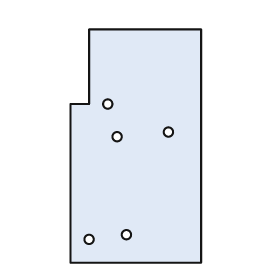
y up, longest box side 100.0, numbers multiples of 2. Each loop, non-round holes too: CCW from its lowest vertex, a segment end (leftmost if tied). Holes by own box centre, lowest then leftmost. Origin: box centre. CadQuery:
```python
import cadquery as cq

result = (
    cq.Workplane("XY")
    .moveTo(-28.0, -50.0)
    .lineTo(28.0, -50.0)
    .lineTo(28.0, 50.0)
    .lineTo(-20.0, 50.0)
    .lineTo(-20.0, 18.0)
    .lineTo(-28.0, 18.0)
    .close()
    .moveTo(-20.0, -40.0)
    .circle(2.0)
    .moveTo(-4.0, -38.0)
    .circle(2.0)
    .moveTo(-8.0, 4.0)
    .circle(2.0)
    .moveTo(14.0, 6.0)
    .circle(2.0)
    .moveTo(-12.0, 18.0)
    .circle(2.0)
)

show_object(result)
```